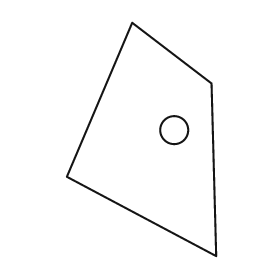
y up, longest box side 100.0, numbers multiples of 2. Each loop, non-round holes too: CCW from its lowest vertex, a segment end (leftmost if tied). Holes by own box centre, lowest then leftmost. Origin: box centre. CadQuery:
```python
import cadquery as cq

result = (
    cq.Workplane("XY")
    .moveTo(32.0, -50.0)
    .lineTo(30.0, 24.0)
    .lineTo(-4.0, 50.0)
    .lineTo(-32.0, -16.0)
    .close()
    .moveTo(14.0, 4.0)
    .circle(6.0)
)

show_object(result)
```